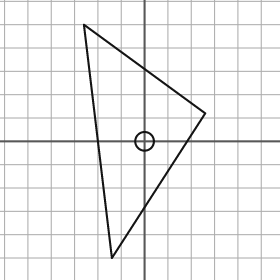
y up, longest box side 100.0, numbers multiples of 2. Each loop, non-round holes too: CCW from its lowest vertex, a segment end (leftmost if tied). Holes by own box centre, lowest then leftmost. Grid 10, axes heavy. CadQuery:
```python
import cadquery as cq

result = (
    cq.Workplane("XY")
    .moveTo(-14.0, -50.0)
    .lineTo(26.0, 12.0)
    .lineTo(-26.0, 50.0)
    .close()
    .moveTo(0.0, 0.0)
    .circle(4.0)
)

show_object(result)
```